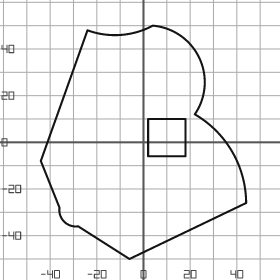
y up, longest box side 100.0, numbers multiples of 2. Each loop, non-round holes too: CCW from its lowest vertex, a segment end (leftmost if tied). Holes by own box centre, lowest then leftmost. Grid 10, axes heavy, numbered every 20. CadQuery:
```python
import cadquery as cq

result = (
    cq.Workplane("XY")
    .moveTo(-6.0, -50.0)
    .lineTo(44.0, -26.0)
    .threePointArc((38.0, -4.0), (22.0, 12.0))
    .threePointArc((24.0, 36.0), (4.0, 50.0))
    .threePointArc((-10.0, 46.0), (-24.0, 48.0))
    .lineTo(-44.0, -8.0)
    .lineTo(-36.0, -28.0)
    .threePointArc((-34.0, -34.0), (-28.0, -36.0))
    .close()
    .moveTo(2.0, -6.0)
    .lineTo(18.0, -6.0)
    .lineTo(18.0, 10.0)
    .lineTo(2.0, 10.0)
    .close()
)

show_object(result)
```